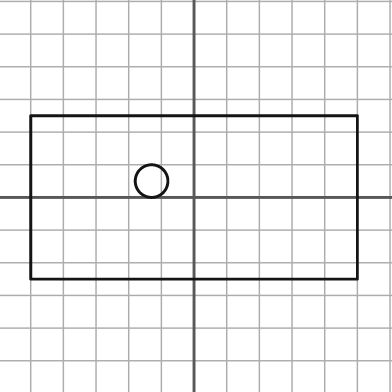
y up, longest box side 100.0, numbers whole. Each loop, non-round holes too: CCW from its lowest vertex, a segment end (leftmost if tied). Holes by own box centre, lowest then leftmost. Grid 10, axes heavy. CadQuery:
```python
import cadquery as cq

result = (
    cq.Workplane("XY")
    .moveTo(-50.0, -25.0)
    .lineTo(50.0, -25.0)
    .lineTo(50.0, 25.0)
    .lineTo(-50.0, 25.0)
    .close()
    .moveTo(-13.0, 5.0)
    .circle(5.0)
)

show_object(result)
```